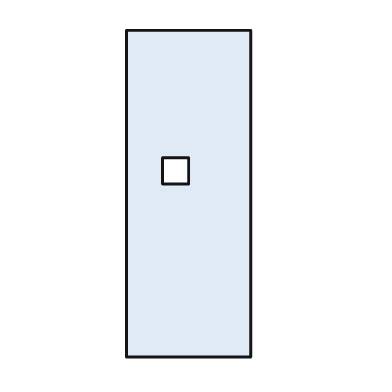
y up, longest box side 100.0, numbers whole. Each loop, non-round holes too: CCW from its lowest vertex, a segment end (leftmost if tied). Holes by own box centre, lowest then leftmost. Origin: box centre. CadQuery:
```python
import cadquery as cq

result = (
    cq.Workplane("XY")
    .moveTo(-19.0, -50.0)
    .lineTo(19.0, -50.0)
    .lineTo(19.0, 50.0)
    .lineTo(-19.0, 50.0)
    .close()
    .moveTo(-8.0, 3.0)
    .lineTo(0.0, 3.0)
    .lineTo(0.0, 11.0)
    .lineTo(-8.0, 11.0)
    .close()
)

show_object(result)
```